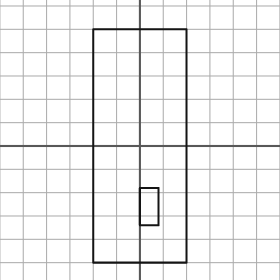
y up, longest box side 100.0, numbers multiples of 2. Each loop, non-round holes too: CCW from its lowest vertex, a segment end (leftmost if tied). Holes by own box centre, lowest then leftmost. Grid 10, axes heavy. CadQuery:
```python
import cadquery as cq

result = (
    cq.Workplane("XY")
    .moveTo(-20.0, -50.0)
    .lineTo(20.0, -50.0)
    .lineTo(20.0, 50.0)
    .lineTo(-20.0, 50.0)
    .close()
    .moveTo(0.0, -34.0)
    .lineTo(8.0, -34.0)
    .lineTo(8.0, -18.0)
    .lineTo(0.0, -18.0)
    .close()
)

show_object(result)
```